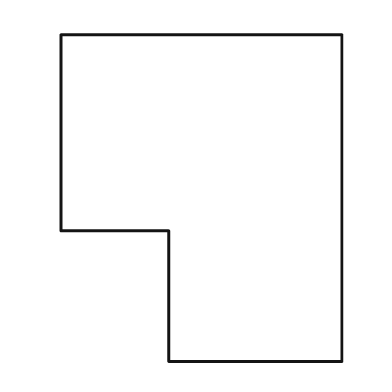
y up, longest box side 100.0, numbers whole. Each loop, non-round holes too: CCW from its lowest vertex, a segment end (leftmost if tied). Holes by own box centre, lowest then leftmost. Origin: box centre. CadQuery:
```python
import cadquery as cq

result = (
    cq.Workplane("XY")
    .moveTo(-10.0, -50.0)
    .lineTo(43.0, -50.0)
    .lineTo(43.0, 50.0)
    .lineTo(-43.0, 50.0)
    .lineTo(-43.0, -10.0)
    .lineTo(-10.0, -10.0)
    .close()
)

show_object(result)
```